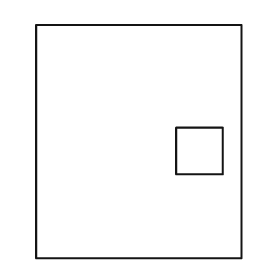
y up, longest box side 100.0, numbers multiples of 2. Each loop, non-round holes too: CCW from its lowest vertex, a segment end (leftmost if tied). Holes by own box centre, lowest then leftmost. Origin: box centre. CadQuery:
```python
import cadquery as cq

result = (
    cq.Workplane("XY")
    .moveTo(-44.0, -50.0)
    .lineTo(44.0, -50.0)
    .lineTo(44.0, 50.0)
    .lineTo(-44.0, 50.0)
    .close()
    .moveTo(16.0, -14.0)
    .lineTo(36.0, -14.0)
    .lineTo(36.0, 6.0)
    .lineTo(16.0, 6.0)
    .close()
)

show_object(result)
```